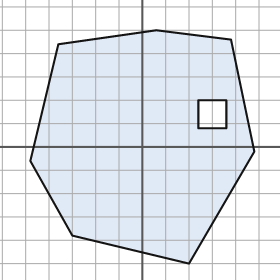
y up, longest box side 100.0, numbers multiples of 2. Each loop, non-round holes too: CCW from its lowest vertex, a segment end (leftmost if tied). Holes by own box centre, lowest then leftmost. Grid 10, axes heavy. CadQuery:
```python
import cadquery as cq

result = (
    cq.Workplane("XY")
    .moveTo(20.0, -50.0)
    .lineTo(48.0, -2.0)
    .lineTo(38.0, 46.0)
    .lineTo(6.0, 50.0)
    .lineTo(-36.0, 44.0)
    .lineTo(-48.0, -6.0)
    .lineTo(-30.0, -38.0)
    .close()
    .moveTo(24.0, 8.0)
    .lineTo(36.0, 8.0)
    .lineTo(36.0, 20.0)
    .lineTo(24.0, 20.0)
    .close()
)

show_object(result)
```